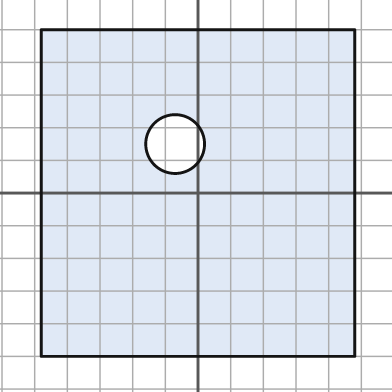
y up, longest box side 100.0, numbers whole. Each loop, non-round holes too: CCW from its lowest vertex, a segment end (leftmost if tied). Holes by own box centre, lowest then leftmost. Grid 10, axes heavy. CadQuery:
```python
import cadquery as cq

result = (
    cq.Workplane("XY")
    .moveTo(-48.0, -50.0)
    .lineTo(48.0, -50.0)
    .lineTo(48.0, 50.0)
    .lineTo(-48.0, 50.0)
    .close()
    .moveTo(-7.0, 15.0)
    .circle(9.0)
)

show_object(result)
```